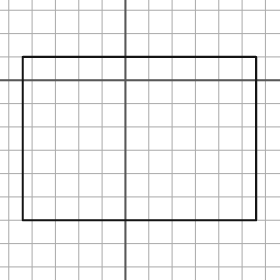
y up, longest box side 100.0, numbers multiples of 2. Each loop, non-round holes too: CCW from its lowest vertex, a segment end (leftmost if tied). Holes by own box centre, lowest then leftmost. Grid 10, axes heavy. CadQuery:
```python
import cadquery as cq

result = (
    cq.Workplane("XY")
    .moveTo(-44.0, -60.0)
    .lineTo(56.0, -60.0)
    .lineTo(56.0, 10.0)
    .lineTo(-44.0, 10.0)
    .close()
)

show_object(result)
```